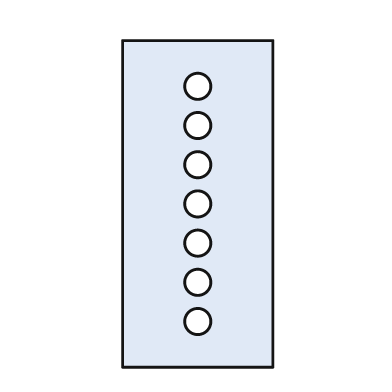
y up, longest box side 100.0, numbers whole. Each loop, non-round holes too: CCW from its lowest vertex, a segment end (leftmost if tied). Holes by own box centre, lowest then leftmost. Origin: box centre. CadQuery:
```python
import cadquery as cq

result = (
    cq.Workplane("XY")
    .moveTo(-23.0, -50.0)
    .lineTo(23.0, -50.0)
    .lineTo(23.0, 50.0)
    .lineTo(-23.0, 50.0)
    .close()
    .moveTo(0.0, -36.0)
    .circle(4.0)
    .moveTo(0.0, -24.0)
    .circle(4.0)
    .moveTo(0.0, -12.0)
    .circle(4.0)
    .moveTo(0.0, 0.0)
    .circle(4.0)
    .moveTo(0.0, 12.0)
    .circle(4.0)
    .moveTo(0.0, 24.0)
    .circle(4.0)
    .moveTo(0.0, 36.0)
    .circle(4.0)
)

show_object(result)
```